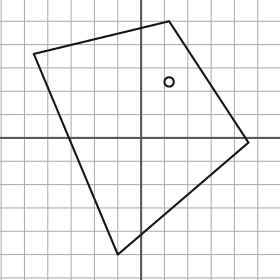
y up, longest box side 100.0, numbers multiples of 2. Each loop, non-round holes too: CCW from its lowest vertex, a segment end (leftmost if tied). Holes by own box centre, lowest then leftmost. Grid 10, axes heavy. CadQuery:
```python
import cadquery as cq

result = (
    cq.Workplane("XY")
    .moveTo(-10.0, -50.0)
    .lineTo(46.0, -2.0)
    .lineTo(12.0, 50.0)
    .lineTo(-46.0, 36.0)
    .close()
    .moveTo(12.0, 24.0)
    .circle(2.0)
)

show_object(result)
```